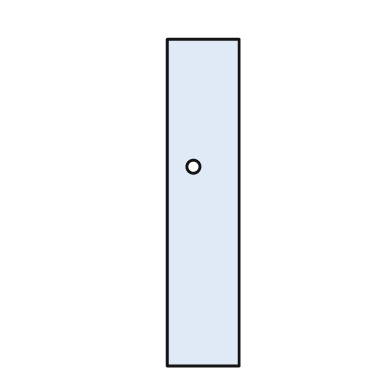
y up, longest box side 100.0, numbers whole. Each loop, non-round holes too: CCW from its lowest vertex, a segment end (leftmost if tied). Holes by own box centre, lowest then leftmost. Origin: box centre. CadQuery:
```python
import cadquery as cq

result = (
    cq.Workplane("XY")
    .moveTo(-11.0, -50.0)
    .lineTo(11.0, -50.0)
    .lineTo(11.0, 50.0)
    .lineTo(-11.0, 50.0)
    .close()
    .moveTo(-3.0, 11.0)
    .circle(2.0)
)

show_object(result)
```